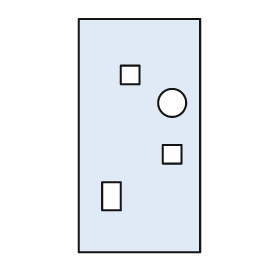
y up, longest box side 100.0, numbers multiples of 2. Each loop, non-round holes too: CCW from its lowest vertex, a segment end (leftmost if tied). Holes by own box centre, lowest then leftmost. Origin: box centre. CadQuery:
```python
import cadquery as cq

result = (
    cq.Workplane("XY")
    .moveTo(-26.0, -50.0)
    .lineTo(26.0, -50.0)
    .lineTo(26.0, 50.0)
    .lineTo(-26.0, 50.0)
    .close()
    .moveTo(-16.0, -32.0)
    .lineTo(-8.0, -32.0)
    .lineTo(-8.0, -20.0)
    .lineTo(-16.0, -20.0)
    .close()
    .moveTo(10.0, -12.0)
    .lineTo(18.0, -12.0)
    .lineTo(18.0, -4.0)
    .lineTo(10.0, -4.0)
    .close()
    .moveTo(14.0, 14.0)
    .circle(6.0)
    .moveTo(-8.0, 22.0)
    .lineTo(0.0, 22.0)
    .lineTo(0.0, 30.0)
    .lineTo(-8.0, 30.0)
    .close()
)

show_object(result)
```